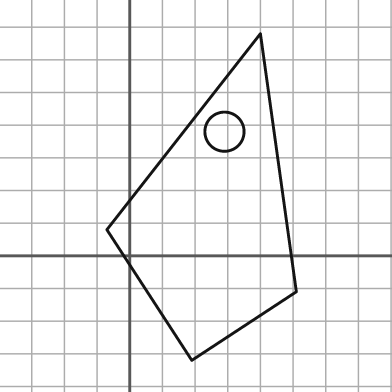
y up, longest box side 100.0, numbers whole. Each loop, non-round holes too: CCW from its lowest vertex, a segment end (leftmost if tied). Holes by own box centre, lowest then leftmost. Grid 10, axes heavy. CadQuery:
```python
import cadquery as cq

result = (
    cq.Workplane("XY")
    .moveTo(19.0, -32.0)
    .lineTo(51.0, -11.0)
    .lineTo(40.0, 68.0)
    .lineTo(-7.0, 8.0)
    .close()
    .moveTo(29.0, 38.0)
    .circle(6.0)
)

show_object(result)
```